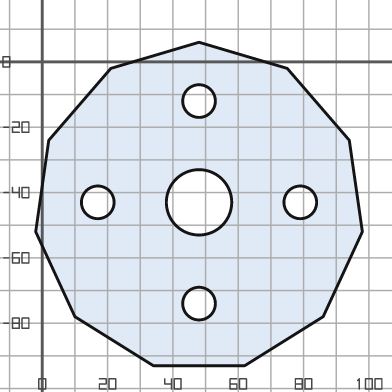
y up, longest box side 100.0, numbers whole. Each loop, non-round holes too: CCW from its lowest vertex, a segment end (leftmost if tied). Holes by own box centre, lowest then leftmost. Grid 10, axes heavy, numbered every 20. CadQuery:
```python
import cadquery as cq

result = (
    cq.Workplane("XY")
    .moveTo(34.0, -93.0)
    .lineTo(62.0, -93.0)
    .lineTo(86.0, -78.0)
    .lineTo(98.0, -52.0)
    .lineTo(94.0, -24.0)
    .lineTo(75.0, -2.0)
    .lineTo(48.0, 6.0)
    .lineTo(21.0, -2.0)
    .lineTo(2.0, -24.0)
    .lineTo(-2.0, -52.0)
    .lineTo(10.0, -78.0)
    .close()
    .moveTo(48.0, -74.0)
    .circle(5.0)
    .moveTo(17.0, -43.0)
    .circle(5.0)
    .moveTo(48.0, -43.0)
    .circle(10.0)
    .moveTo(79.0, -43.0)
    .circle(5.0)
    .moveTo(48.0, -12.0)
    .circle(5.0)
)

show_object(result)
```